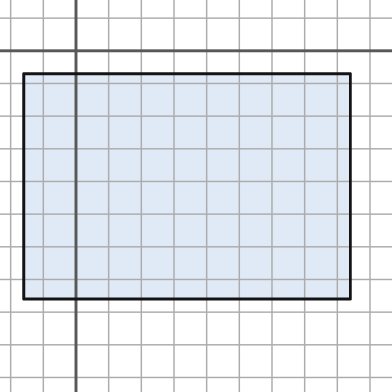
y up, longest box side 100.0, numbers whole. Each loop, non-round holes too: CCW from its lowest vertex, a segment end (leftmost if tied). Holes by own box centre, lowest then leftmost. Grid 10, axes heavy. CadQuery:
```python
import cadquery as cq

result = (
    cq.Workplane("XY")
    .moveTo(-16.0, -76.0)
    .lineTo(84.0, -76.0)
    .lineTo(84.0, -7.0)
    .lineTo(-16.0, -7.0)
    .close()
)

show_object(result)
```